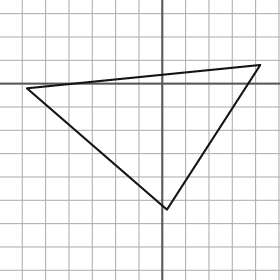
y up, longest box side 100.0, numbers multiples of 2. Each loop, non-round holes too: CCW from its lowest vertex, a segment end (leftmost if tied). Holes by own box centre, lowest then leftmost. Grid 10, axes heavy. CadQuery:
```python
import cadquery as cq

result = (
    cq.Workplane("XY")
    .moveTo(2.0, -54.0)
    .lineTo(42.0, 8.0)
    .lineTo(-58.0, -2.0)
    .close()
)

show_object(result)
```